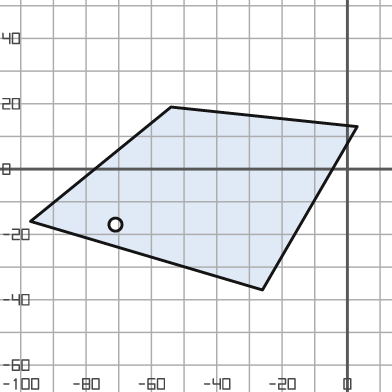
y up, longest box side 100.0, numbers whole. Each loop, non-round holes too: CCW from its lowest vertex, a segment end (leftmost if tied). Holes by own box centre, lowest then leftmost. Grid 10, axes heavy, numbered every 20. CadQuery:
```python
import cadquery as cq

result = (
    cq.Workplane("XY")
    .moveTo(-26.0, -37.0)
    .lineTo(3.0, 13.0)
    .lineTo(-54.0, 19.0)
    .lineTo(-97.0, -16.0)
    .close()
    .moveTo(-71.0, -17.0)
    .circle(2.0)
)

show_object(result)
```